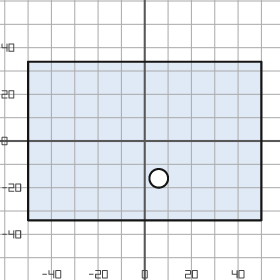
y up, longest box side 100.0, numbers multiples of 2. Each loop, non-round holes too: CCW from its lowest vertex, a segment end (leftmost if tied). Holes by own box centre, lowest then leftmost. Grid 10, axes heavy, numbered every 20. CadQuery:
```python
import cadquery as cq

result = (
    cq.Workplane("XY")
    .moveTo(-50.0, -34.0)
    .lineTo(50.0, -34.0)
    .lineTo(50.0, 34.0)
    .lineTo(-50.0, 34.0)
    .close()
    .moveTo(6.0, -16.0)
    .circle(4.0)
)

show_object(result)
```